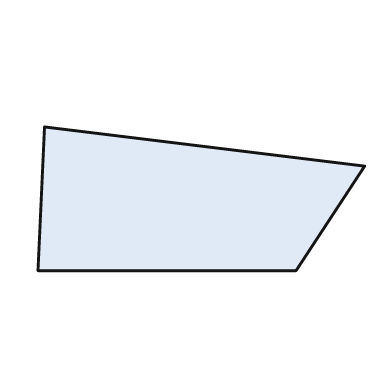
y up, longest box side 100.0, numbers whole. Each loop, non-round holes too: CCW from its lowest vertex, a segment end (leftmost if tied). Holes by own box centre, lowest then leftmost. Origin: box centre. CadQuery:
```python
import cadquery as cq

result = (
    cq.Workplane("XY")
    .moveTo(-50.0, -22.0)
    .lineTo(29.0, -22.0)
    .lineTo(50.0, 10.0)
    .lineTo(-48.0, 22.0)
    .close()
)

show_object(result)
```